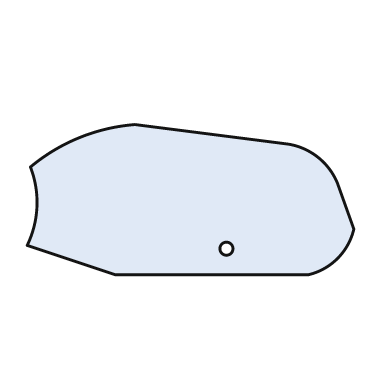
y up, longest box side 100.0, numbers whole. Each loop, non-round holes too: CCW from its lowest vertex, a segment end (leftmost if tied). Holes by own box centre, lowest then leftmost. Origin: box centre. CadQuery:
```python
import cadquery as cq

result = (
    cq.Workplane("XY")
    .moveTo(-23.0, -23.0)
    .lineTo(36.0, -23.0)
    .threePointArc((45.0, -18.0), (50.0, -9.0))
    .lineTo(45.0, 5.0)
    .threePointArc((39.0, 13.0), (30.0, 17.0))
    .lineTo(-17.0, 23.0)
    .threePointArc((-34.0, 19.0), (-49.0, 10.0))
    .threePointArc((-47.0, -2.0), (-50.0, -14.0))
    .close()
    .moveTo(11.0, -15.0)
    .circle(2.0)
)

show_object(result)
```